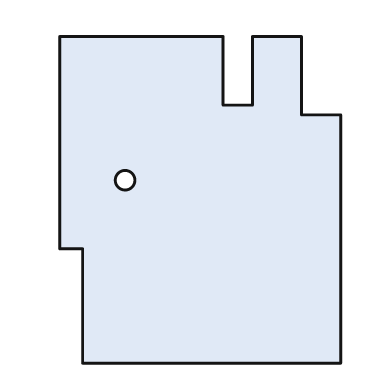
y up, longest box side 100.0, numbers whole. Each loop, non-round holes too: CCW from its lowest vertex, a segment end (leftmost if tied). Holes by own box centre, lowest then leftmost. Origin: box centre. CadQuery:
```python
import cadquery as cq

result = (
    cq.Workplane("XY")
    .moveTo(-36.0, -50.0)
    .lineTo(43.0, -50.0)
    .lineTo(43.0, 26.0)
    .lineTo(31.0, 26.0)
    .lineTo(31.0, 50.0)
    .lineTo(16.0, 50.0)
    .lineTo(16.0, 29.0)
    .lineTo(7.0, 29.0)
    .lineTo(7.0, 50.0)
    .lineTo(-43.0, 50.0)
    .lineTo(-43.0, -15.0)
    .lineTo(-36.0, -15.0)
    .close()
    .moveTo(-23.0, 6.0)
    .circle(3.0)
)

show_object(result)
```